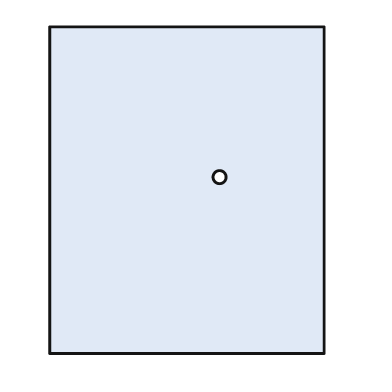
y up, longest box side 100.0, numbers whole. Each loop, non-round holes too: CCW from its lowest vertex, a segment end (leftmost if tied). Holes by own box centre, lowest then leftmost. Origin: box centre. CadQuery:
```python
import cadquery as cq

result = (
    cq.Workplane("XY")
    .moveTo(-42.0, -50.0)
    .lineTo(42.0, -50.0)
    .lineTo(42.0, 50.0)
    .lineTo(-42.0, 50.0)
    .close()
    .moveTo(10.0, 4.0)
    .circle(2.0)
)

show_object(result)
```